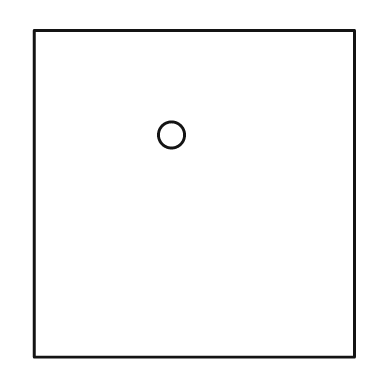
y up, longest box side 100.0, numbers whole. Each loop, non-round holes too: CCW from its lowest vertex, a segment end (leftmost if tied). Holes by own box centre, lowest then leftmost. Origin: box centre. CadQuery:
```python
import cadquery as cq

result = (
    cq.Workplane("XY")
    .moveTo(-49.0, -50.0)
    .lineTo(49.0, -50.0)
    .lineTo(49.0, 50.0)
    .lineTo(-49.0, 50.0)
    .close()
    .moveTo(-7.0, 18.0)
    .circle(4.0)
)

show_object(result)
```